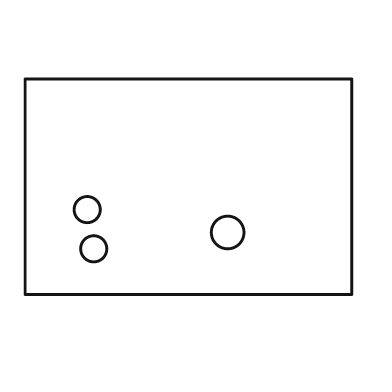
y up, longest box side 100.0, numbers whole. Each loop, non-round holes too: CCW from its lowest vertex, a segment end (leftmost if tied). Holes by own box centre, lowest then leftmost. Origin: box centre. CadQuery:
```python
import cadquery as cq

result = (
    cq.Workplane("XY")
    .moveTo(-50.0, -33.0)
    .lineTo(50.0, -33.0)
    .lineTo(50.0, 33.0)
    .lineTo(-50.0, 33.0)
    .close()
    .moveTo(-29.0, -19.0)
    .circle(4.0)
    .moveTo(12.0, -14.0)
    .circle(5.0)
    .moveTo(-31.0, -7.0)
    .circle(4.0)
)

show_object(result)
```